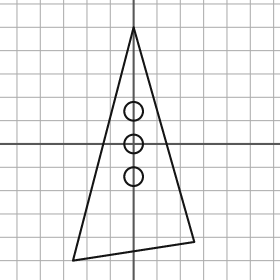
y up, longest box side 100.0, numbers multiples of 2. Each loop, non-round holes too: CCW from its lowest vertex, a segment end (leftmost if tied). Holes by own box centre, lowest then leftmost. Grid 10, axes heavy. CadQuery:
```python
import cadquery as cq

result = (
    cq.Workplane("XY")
    .moveTo(-26.0, -50.0)
    .lineTo(26.0, -42.0)
    .lineTo(0.0, 50.0)
    .close()
    .moveTo(0.0, -14.0)
    .circle(4.0)
    .moveTo(0.0, 0.0)
    .circle(4.0)
    .moveTo(0.0, 14.0)
    .circle(4.0)
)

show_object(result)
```